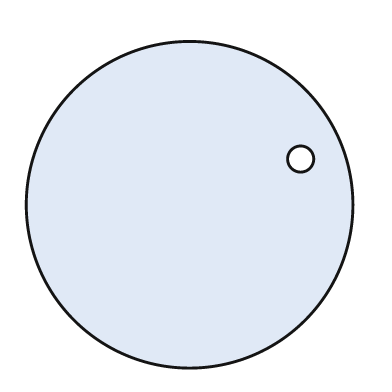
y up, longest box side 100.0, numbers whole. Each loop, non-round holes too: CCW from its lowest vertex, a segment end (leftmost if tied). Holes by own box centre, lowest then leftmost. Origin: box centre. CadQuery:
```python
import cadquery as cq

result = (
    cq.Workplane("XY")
    .moveTo(0.0, 0.0)
    .circle(50.0)
    .moveTo(34.0, 14.0)
    .circle(4.0)
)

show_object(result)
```